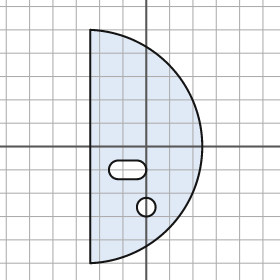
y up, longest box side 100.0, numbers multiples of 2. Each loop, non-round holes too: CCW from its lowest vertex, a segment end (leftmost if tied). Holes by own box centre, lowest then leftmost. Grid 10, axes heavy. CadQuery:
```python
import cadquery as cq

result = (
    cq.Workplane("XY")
    .moveTo(-24.0, -50.0)
    .threePointArc((24.0, 0.0), (-24.0, 50.0))
    .close()
    .moveTo(0.0, -26.0)
    .circle(4.0)
    .moveTo(-12.0, -14.0)
    .lineTo(-4.0, -14.0)
    .threePointArc((0.0, -10.0), (-4.0, -6.0))
    .lineTo(-12.0, -6.0)
    .threePointArc((-16.0, -10.0), (-12.0, -14.0))
    .close()
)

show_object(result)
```